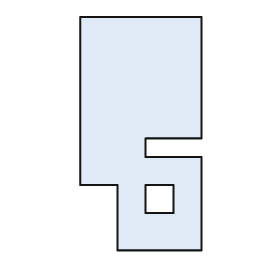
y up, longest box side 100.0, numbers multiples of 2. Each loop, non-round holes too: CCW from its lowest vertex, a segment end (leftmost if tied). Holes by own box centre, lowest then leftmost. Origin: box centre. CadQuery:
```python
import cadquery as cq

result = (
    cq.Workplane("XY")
    .moveTo(-10.0, -50.0)
    .lineTo(26.0, -50.0)
    .lineTo(26.0, -10.0)
    .lineTo(2.0, -10.0)
    .lineTo(2.0, -2.0)
    .lineTo(26.0, -2.0)
    .lineTo(26.0, 50.0)
    .lineTo(-26.0, 50.0)
    .lineTo(-26.0, -22.0)
    .lineTo(-10.0, -22.0)
    .close()
    .moveTo(2.0, -34.0)
    .lineTo(14.0, -34.0)
    .lineTo(14.0, -22.0)
    .lineTo(2.0, -22.0)
    .close()
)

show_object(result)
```